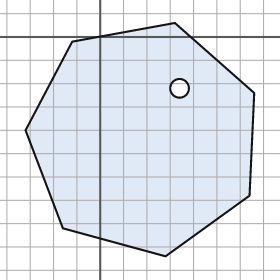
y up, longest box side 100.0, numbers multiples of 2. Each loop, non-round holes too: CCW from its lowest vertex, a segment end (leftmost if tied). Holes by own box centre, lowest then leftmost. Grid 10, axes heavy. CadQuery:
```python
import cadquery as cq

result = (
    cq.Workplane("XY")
    .moveTo(28.0, -94.0)
    .lineTo(64.0, -68.0)
    .lineTo(66.0, -24.0)
    .lineTo(32.0, 6.0)
    .lineTo(-12.0, -2.0)
    .lineTo(-32.0, -40.0)
    .lineTo(-16.0, -82.0)
    .close()
    .moveTo(34.0, -22.0)
    .circle(4.0)
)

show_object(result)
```